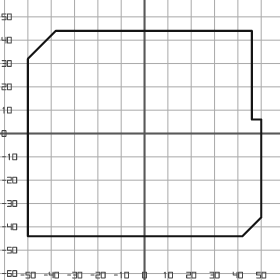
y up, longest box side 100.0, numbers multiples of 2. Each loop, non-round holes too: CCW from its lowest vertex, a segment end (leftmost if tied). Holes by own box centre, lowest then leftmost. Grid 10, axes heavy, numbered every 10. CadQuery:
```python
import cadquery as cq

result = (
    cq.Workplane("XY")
    .moveTo(-50.0, -44.0)
    .lineTo(42.0, -44.0)
    .lineTo(50.0, -36.0)
    .lineTo(50.0, 6.0)
    .lineTo(46.0, 6.0)
    .lineTo(46.0, 44.0)
    .lineTo(-38.0, 44.0)
    .lineTo(-50.0, 32.0)
    .close()
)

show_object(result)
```